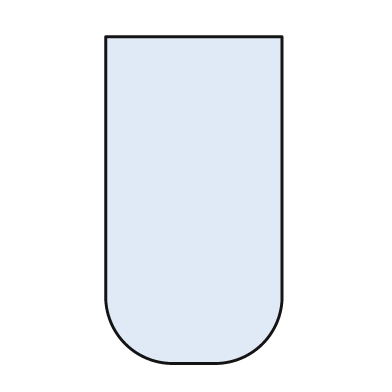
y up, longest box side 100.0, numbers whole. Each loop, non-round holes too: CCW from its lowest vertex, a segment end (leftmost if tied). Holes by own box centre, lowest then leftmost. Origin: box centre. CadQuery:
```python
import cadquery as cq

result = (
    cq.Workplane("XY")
    .moveTo(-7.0, -50.0)
    .lineTo(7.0, -50.0)
    .threePointArc((21.0, -44.0), (27.0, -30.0))
    .lineTo(27.0, 50.0)
    .lineTo(-27.0, 50.0)
    .lineTo(-27.0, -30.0)
    .threePointArc((-21.0, -44.0), (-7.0, -50.0))
    .close()
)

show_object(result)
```